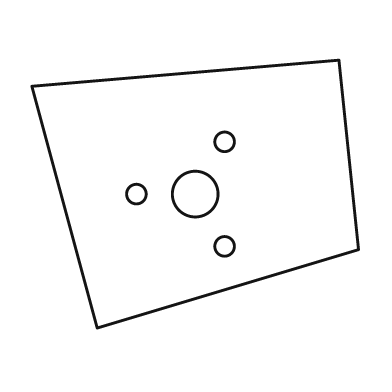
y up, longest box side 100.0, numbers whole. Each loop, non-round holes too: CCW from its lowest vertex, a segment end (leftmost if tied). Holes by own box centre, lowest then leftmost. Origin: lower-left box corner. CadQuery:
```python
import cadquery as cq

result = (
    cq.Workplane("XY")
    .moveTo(20.0, 0.0)
    .lineTo(100.0, 24.0)
    .lineTo(94.0, 82.0)
    .lineTo(0.0, 74.0)
    .close()
    .moveTo(59.0, 25.0)
    .circle(3.0)
    .moveTo(32.0, 41.0)
    .circle(3.0)
    .moveTo(50.0, 41.0)
    .circle(7.0)
    .moveTo(59.0, 57.0)
    .circle(3.0)
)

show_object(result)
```